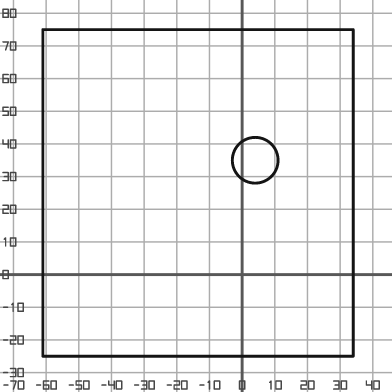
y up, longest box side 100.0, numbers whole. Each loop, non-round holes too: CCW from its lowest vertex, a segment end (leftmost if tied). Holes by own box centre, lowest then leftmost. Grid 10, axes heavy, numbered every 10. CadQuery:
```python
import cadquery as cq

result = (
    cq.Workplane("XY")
    .moveTo(-61.0, -25.0)
    .lineTo(34.0, -25.0)
    .lineTo(34.0, 75.0)
    .lineTo(-61.0, 75.0)
    .close()
    .moveTo(4.0, 35.0)
    .circle(7.0)
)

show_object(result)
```